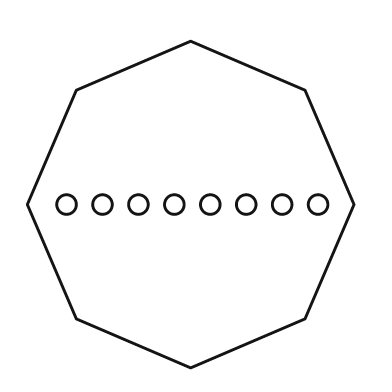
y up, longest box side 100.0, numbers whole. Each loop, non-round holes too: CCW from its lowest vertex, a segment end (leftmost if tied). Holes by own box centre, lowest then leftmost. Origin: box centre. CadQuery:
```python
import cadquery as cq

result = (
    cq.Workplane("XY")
    .moveTo(0.0, -50.0)
    .lineTo(35.0, -35.0)
    .lineTo(50.0, 0.0)
    .lineTo(35.0, 35.0)
    .lineTo(0.0, 50.0)
    .lineTo(-35.0, 35.0)
    .lineTo(-50.0, 0.0)
    .lineTo(-35.0, -35.0)
    .close()
    .moveTo(-38.0, 0.0)
    .circle(3.0)
    .moveTo(-27.0, 0.0)
    .circle(3.0)
    .moveTo(-16.0, 0.0)
    .circle(3.0)
    .moveTo(-5.0, 0.0)
    .circle(3.0)
    .moveTo(6.0, 0.0)
    .circle(3.0)
    .moveTo(17.0, 0.0)
    .circle(3.0)
    .moveTo(28.0, 0.0)
    .circle(3.0)
    .moveTo(39.0, 0.0)
    .circle(3.0)
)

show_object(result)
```